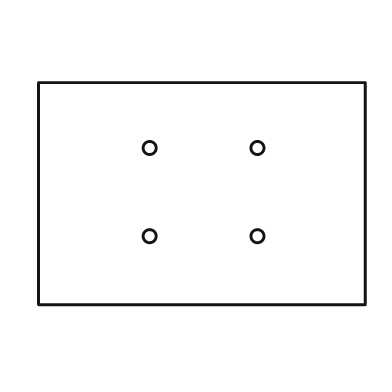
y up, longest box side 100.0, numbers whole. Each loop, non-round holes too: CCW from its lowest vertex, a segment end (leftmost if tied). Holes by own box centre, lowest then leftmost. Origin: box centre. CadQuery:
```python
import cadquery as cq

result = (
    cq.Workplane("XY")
    .moveTo(-50.0, -34.0)
    .lineTo(50.0, -34.0)
    .lineTo(50.0, 34.0)
    .lineTo(-50.0, 34.0)
    .close()
    .moveTo(-16.0, -13.0)
    .circle(2.0)
    .moveTo(17.0, -13.0)
    .circle(2.0)
    .moveTo(-16.0, 14.0)
    .circle(2.0)
    .moveTo(17.0, 14.0)
    .circle(2.0)
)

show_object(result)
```